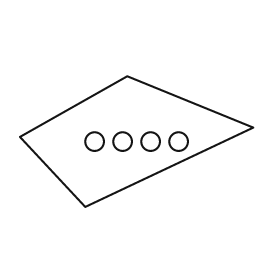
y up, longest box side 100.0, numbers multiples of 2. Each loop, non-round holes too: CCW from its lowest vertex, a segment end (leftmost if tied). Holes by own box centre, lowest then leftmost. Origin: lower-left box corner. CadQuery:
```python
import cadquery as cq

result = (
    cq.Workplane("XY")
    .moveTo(28.0, 0.0)
    .lineTo(100.0, 34.0)
    .lineTo(46.0, 56.0)
    .lineTo(0.0, 30.0)
    .close()
    .moveTo(32.0, 28.0)
    .circle(4.0)
    .moveTo(44.0, 28.0)
    .circle(4.0)
    .moveTo(56.0, 28.0)
    .circle(4.0)
    .moveTo(68.0, 28.0)
    .circle(4.0)
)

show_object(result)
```